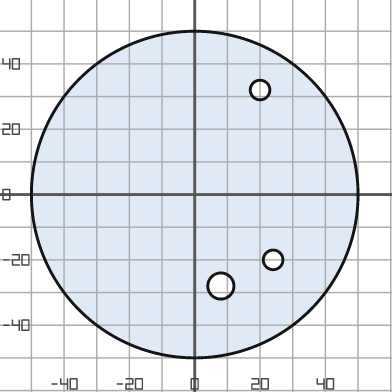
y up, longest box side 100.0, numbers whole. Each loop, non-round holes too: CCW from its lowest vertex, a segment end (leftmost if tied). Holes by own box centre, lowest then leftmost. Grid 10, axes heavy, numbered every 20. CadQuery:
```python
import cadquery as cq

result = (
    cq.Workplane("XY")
    .moveTo(0.0, 0.0)
    .circle(50.0)
    .moveTo(8.0, -28.0)
    .circle(4.0)
    .moveTo(24.0, -20.0)
    .circle(3.0)
    .moveTo(20.0, 32.0)
    .circle(3.0)
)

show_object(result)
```